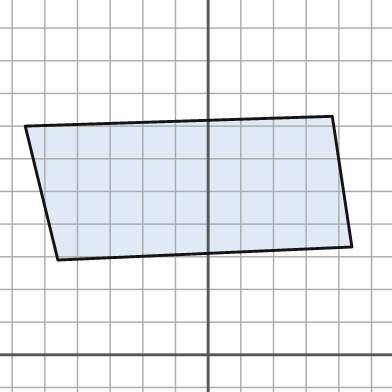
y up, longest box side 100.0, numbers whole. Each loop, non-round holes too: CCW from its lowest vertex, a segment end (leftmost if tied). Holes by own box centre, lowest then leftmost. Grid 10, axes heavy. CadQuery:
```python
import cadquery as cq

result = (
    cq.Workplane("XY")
    .moveTo(-46.0, 29.0)
    .lineTo(44.0, 33.0)
    .lineTo(38.0, 73.0)
    .lineTo(-56.0, 70.0)
    .close()
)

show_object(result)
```